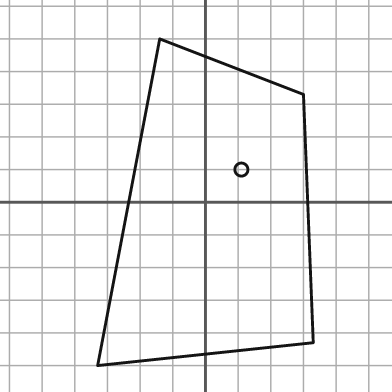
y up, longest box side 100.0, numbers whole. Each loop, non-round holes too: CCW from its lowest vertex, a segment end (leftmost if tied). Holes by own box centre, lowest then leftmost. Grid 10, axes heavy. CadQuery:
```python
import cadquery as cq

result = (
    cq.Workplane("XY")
    .moveTo(-33.0, -50.0)
    .lineTo(33.0, -43.0)
    .lineTo(30.0, 33.0)
    .lineTo(-14.0, 50.0)
    .close()
    .moveTo(11.0, 10.0)
    .circle(2.0)
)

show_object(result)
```